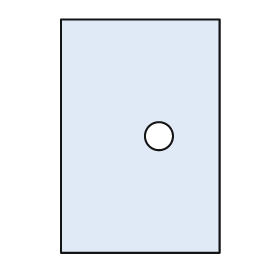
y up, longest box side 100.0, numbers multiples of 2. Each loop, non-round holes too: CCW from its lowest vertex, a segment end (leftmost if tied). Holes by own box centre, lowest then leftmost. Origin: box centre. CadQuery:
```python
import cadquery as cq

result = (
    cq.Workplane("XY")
    .moveTo(-34.0, -50.0)
    .lineTo(34.0, -50.0)
    .lineTo(34.0, 50.0)
    .lineTo(-34.0, 50.0)
    .close()
    .moveTo(8.0, 0.0)
    .circle(6.0)
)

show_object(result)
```